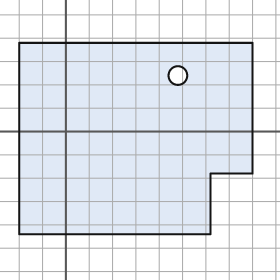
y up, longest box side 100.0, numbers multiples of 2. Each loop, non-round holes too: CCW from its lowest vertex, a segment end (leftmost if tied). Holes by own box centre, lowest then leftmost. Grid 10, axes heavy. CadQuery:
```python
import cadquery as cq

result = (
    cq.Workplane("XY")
    .moveTo(-20.0, -44.0)
    .lineTo(62.0, -44.0)
    .lineTo(62.0, -18.0)
    .lineTo(80.0, -18.0)
    .lineTo(80.0, 38.0)
    .lineTo(-20.0, 38.0)
    .close()
    .moveTo(48.0, 24.0)
    .circle(4.0)
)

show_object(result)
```